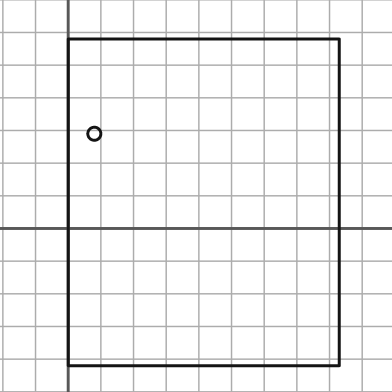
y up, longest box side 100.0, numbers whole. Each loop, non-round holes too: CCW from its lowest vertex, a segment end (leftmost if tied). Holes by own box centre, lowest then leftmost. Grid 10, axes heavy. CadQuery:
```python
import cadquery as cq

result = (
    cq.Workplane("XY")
    .moveTo(0.0, -42.0)
    .lineTo(83.0, -42.0)
    .lineTo(83.0, 58.0)
    .lineTo(0.0, 58.0)
    .close()
    .moveTo(8.0, 29.0)
    .circle(2.0)
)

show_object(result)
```